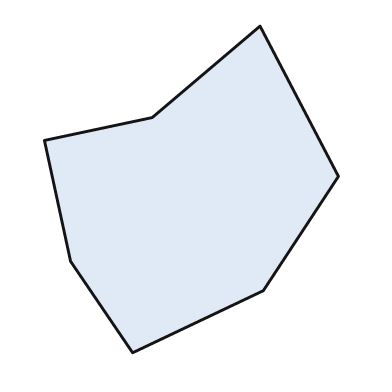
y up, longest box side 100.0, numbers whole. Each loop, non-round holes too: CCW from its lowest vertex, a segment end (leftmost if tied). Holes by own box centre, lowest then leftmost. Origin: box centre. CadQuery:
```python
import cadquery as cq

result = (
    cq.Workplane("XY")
    .moveTo(-18.0, -50.0)
    .lineTo(22.0, -31.0)
    .lineTo(45.0, 4.0)
    .lineTo(21.0, 50.0)
    .lineTo(-12.0, 22.0)
    .lineTo(-45.0, 15.0)
    .lineTo(-37.0, -22.0)
    .close()
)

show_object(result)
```